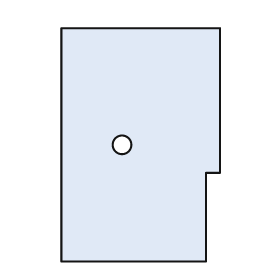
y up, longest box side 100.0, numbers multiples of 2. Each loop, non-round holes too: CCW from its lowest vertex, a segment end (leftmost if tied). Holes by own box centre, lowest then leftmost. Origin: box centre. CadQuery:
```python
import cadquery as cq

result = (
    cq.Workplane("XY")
    .moveTo(-34.0, -50.0)
    .lineTo(28.0, -50.0)
    .lineTo(28.0, -12.0)
    .lineTo(34.0, -12.0)
    .lineTo(34.0, 50.0)
    .lineTo(-34.0, 50.0)
    .close()
    .moveTo(-8.0, 0.0)
    .circle(4.0)
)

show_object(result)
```